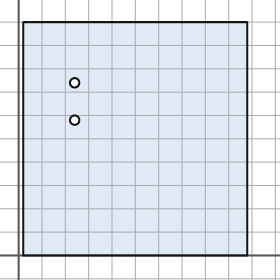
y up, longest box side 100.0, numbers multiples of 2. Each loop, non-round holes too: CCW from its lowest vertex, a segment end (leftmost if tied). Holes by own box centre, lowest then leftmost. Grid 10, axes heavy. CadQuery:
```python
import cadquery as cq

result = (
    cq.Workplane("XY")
    .moveTo(2.0, 0.0)
    .lineTo(98.0, 0.0)
    .lineTo(98.0, 100.0)
    .lineTo(2.0, 100.0)
    .close()
    .moveTo(24.0, 58.0)
    .circle(2.0)
    .moveTo(24.0, 74.0)
    .circle(2.0)
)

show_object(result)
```